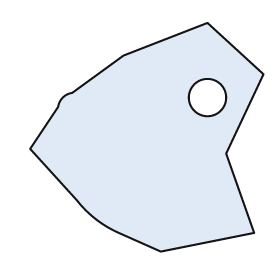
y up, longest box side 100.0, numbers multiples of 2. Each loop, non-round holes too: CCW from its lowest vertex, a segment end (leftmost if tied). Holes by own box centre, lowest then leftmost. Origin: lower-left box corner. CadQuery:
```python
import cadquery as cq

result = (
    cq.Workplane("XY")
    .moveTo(56.0, 0.0)
    .lineTo(96.0, 8.0)
    .lineTo(84.0, 42.0)
    .lineTo(100.0, 76.0)
    .lineTo(76.0, 98.0)
    .lineTo(40.0, 84.0)
    .lineTo(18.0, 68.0)
    .threePointArc((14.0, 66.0), (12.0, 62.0))
    .lineTo(0.0, 44.0)
    .lineTo(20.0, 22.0)
    .threePointArc((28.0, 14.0), (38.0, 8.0))
    .close()
    .moveTo(76.0, 66.0)
    .circle(8.0)
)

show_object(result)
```